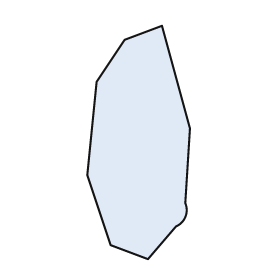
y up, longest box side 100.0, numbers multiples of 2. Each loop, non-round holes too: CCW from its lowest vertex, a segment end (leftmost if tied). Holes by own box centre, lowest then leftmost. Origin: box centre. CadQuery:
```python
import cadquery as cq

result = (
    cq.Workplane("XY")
    .moveTo(4.0, -50.0)
    .lineTo(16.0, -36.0)
    .threePointArc((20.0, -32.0), (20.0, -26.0))
    .lineTo(22.0, 6.0)
    .lineTo(10.0, 50.0)
    .lineTo(-6.0, 44.0)
    .lineTo(-18.0, 26.0)
    .lineTo(-22.0, -14.0)
    .lineTo(-12.0, -44.0)
    .close()
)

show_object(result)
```